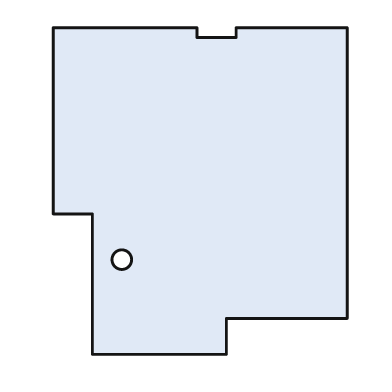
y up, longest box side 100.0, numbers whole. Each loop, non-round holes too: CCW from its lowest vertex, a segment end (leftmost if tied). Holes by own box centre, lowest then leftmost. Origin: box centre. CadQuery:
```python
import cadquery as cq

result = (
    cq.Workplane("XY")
    .moveTo(-33.0, -50.0)
    .lineTo(8.0, -50.0)
    .lineTo(8.0, -39.0)
    .lineTo(45.0, -39.0)
    .lineTo(45.0, 50.0)
    .lineTo(11.0, 50.0)
    .lineTo(11.0, 47.0)
    .lineTo(-1.0, 47.0)
    .lineTo(-1.0, 50.0)
    .lineTo(-45.0, 50.0)
    .lineTo(-45.0, -7.0)
    .lineTo(-33.0, -7.0)
    .close()
    .moveTo(-24.0, -21.0)
    .circle(3.0)
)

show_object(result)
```